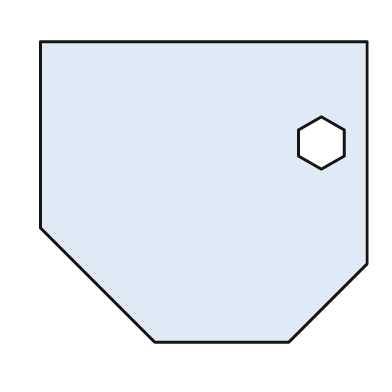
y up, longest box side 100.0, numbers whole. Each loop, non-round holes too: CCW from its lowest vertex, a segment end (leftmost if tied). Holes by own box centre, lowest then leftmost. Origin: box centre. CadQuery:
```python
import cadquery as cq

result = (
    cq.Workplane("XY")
    .moveTo(-15.0, -46.0)
    .lineTo(26.0, -46.0)
    .lineTo(50.0, -22.0)
    .lineTo(50.0, 46.0)
    .lineTo(-50.0, 46.0)
    .lineTo(-50.0, -11.0)
    .close()
    .moveTo(36.0, 7.0)
    .lineTo(43.0, 11.0)
    .lineTo(43.0, 19.0)
    .lineTo(36.0, 23.0)
    .lineTo(29.0, 19.0)
    .lineTo(29.0, 11.0)
    .close()
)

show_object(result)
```